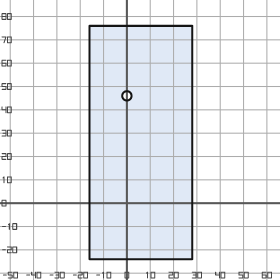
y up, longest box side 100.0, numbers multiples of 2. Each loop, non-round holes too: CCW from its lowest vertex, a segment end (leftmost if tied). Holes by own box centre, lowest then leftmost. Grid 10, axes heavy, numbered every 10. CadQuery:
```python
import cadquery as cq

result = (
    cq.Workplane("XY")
    .moveTo(-16.0, -24.0)
    .lineTo(28.0, -24.0)
    .lineTo(28.0, 76.0)
    .lineTo(-16.0, 76.0)
    .close()
    .moveTo(0.0, 46.0)
    .circle(2.0)
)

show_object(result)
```